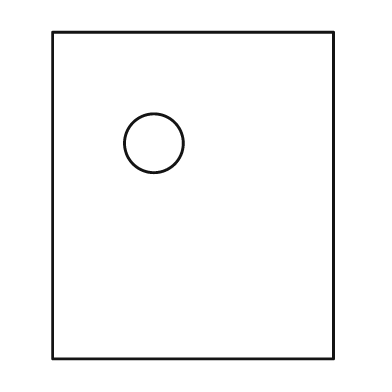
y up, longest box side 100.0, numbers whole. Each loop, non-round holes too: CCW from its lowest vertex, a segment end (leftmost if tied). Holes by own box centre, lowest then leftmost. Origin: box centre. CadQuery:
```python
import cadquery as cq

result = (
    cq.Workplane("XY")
    .moveTo(-43.0, -50.0)
    .lineTo(43.0, -50.0)
    .lineTo(43.0, 50.0)
    .lineTo(-43.0, 50.0)
    .close()
    .moveTo(-12.0, 16.0)
    .circle(9.0)
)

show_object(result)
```